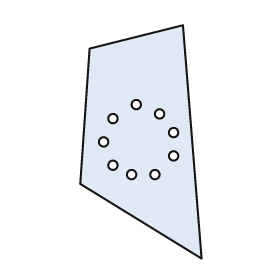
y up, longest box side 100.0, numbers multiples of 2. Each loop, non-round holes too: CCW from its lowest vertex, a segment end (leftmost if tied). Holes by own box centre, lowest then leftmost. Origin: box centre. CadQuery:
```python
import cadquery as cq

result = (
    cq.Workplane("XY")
    .moveTo(26.0, -50.0)
    .lineTo(18.0, 50.0)
    .lineTo(-22.0, 40.0)
    .lineTo(-26.0, -18.0)
    .close()
    .moveTo(-4.0, -14.0)
    .circle(2.0)
    .moveTo(6.0, -14.0)
    .circle(2.0)
    .moveTo(-12.0, -10.0)
    .circle(2.0)
    .moveTo(14.0, -6.0)
    .circle(2.0)
    .moveTo(-16.0, 0.0)
    .circle(2.0)
    .moveTo(14.0, 4.0)
    .circle(2.0)
    .moveTo(-12.0, 10.0)
    .circle(2.0)
    .moveTo(8.0, 12.0)
    .circle(2.0)
    .moveTo(-2.0, 16.0)
    .circle(2.0)
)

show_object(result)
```